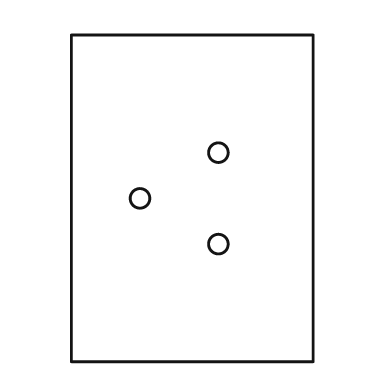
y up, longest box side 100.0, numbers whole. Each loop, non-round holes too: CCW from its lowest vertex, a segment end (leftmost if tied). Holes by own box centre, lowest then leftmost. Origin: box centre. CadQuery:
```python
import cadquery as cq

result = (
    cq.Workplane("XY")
    .moveTo(-37.0, -50.0)
    .lineTo(37.0, -50.0)
    .lineTo(37.0, 50.0)
    .lineTo(-37.0, 50.0)
    .close()
    .moveTo(8.0, -14.0)
    .circle(3.0)
    .moveTo(-16.0, 0.0)
    .circle(3.0)
    .moveTo(8.0, 14.0)
    .circle(3.0)
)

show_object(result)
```